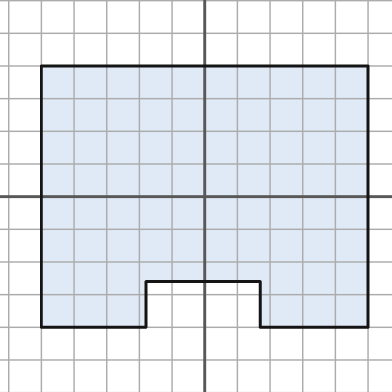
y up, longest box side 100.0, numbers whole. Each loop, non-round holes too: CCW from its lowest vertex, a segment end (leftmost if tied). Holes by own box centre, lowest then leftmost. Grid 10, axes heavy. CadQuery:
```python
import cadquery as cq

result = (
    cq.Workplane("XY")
    .moveTo(-50.0, -40.0)
    .lineTo(-18.0, -40.0)
    .lineTo(-18.0, -26.0)
    .lineTo(17.0, -26.0)
    .lineTo(17.0, -40.0)
    .lineTo(50.0, -40.0)
    .lineTo(50.0, 40.0)
    .lineTo(-50.0, 40.0)
    .close()
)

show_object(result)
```